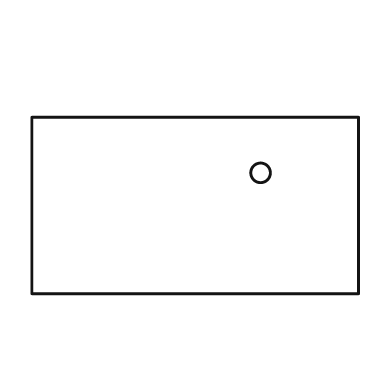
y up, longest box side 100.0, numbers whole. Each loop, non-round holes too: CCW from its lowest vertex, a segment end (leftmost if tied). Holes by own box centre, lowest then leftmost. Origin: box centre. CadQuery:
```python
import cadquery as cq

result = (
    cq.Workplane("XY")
    .moveTo(-50.0, -27.0)
    .lineTo(50.0, -27.0)
    .lineTo(50.0, 27.0)
    .lineTo(-50.0, 27.0)
    .close()
    .moveTo(20.0, 10.0)
    .circle(3.0)
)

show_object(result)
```